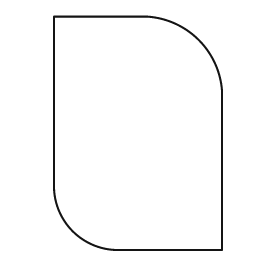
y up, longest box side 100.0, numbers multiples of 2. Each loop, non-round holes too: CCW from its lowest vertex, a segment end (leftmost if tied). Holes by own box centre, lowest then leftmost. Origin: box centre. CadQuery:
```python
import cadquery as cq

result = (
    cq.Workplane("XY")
    .moveTo(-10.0, -50.0)
    .lineTo(36.0, -50.0)
    .lineTo(36.0, 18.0)
    .threePointArc((26.0, 40.0), (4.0, 50.0))
    .lineTo(-36.0, 50.0)
    .lineTo(-36.0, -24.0)
    .threePointArc((-28.0, -42.0), (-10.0, -50.0))
    .close()
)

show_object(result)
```